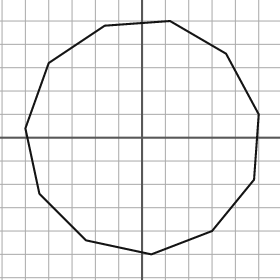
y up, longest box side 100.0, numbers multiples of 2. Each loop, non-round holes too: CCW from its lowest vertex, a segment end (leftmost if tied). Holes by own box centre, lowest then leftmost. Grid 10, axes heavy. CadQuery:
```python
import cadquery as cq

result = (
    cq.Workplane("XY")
    .moveTo(4.0, -50.0)
    .lineTo(30.0, -40.0)
    .lineTo(48.0, -18.0)
    .lineTo(50.0, 10.0)
    .lineTo(36.0, 36.0)
    .lineTo(12.0, 50.0)
    .lineTo(-16.0, 48.0)
    .lineTo(-40.0, 32.0)
    .lineTo(-50.0, 4.0)
    .lineTo(-44.0, -24.0)
    .lineTo(-24.0, -44.0)
    .close()
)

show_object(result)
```